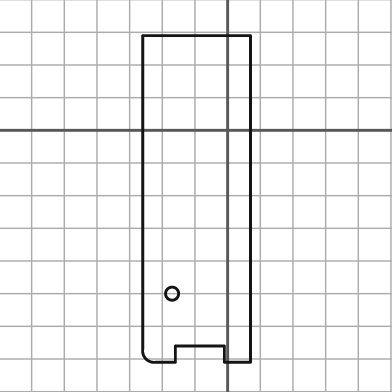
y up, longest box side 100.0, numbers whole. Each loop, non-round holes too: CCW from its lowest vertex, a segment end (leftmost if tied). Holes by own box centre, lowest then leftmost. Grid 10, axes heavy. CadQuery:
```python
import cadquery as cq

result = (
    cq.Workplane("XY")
    .moveTo(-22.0, -71.0)
    .lineTo(-16.0, -71.0)
    .lineTo(-16.0, -66.0)
    .lineTo(-1.0, -66.0)
    .lineTo(-1.0, -71.0)
    .lineTo(7.0, -71.0)
    .lineTo(7.0, 29.0)
    .lineTo(-26.0, 29.0)
    .lineTo(-26.0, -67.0)
    .threePointArc((-25.0, -70.0), (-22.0, -71.0))
    .close()
    .moveTo(-17.0, -50.0)
    .circle(2.0)
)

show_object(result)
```